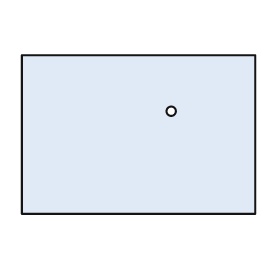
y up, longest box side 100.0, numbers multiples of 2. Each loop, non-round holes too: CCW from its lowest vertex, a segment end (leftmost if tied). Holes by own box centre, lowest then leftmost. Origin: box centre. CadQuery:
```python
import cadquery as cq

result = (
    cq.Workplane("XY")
    .moveTo(-50.0, -34.0)
    .lineTo(50.0, -34.0)
    .lineTo(50.0, 34.0)
    .lineTo(-50.0, 34.0)
    .close()
    .moveTo(14.0, 10.0)
    .circle(2.0)
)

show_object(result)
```